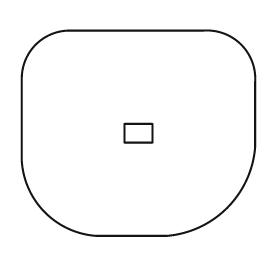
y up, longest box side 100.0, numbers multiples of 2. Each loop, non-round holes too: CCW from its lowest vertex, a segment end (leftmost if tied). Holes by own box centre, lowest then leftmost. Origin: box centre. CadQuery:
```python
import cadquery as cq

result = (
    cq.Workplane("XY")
    .moveTo(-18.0, -44.0)
    .lineTo(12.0, -44.0)
    .threePointArc((38.0, -32.0), (50.0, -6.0))
    .lineTo(50.0, 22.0)
    .threePointArc((44.0, 38.0), (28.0, 44.0))
    .lineTo(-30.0, 44.0)
    .threePointArc((-44.0, 38.0), (-50.0, 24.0))
    .lineTo(-50.0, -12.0)
    .threePointArc((-40.0, -34.0), (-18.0, -44.0))
    .close()
    .moveTo(-6.0, -4.0)
    .lineTo(6.0, -4.0)
    .lineTo(6.0, 4.0)
    .lineTo(-6.0, 4.0)
    .close()
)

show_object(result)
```